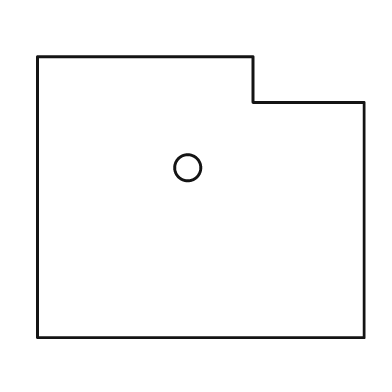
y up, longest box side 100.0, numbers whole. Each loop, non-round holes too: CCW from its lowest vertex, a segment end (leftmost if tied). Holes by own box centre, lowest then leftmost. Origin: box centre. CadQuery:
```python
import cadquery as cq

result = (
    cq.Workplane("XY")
    .moveTo(-50.0, -43.0)
    .lineTo(50.0, -43.0)
    .lineTo(50.0, 29.0)
    .lineTo(16.0, 29.0)
    .lineTo(16.0, 43.0)
    .lineTo(-50.0, 43.0)
    .close()
    .moveTo(-4.0, 9.0)
    .circle(4.0)
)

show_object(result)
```